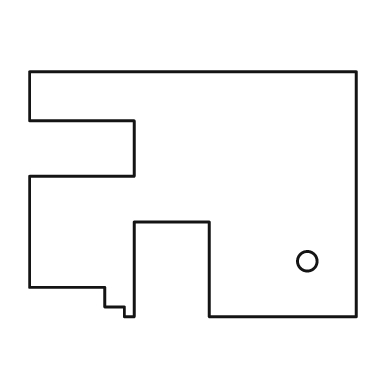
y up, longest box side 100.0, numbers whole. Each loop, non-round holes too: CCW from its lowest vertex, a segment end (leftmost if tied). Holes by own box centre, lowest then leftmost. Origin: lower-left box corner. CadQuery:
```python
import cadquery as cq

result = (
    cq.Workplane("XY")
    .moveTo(29.0, 0.0)
    .lineTo(32.0, 0.0)
    .lineTo(32.0, 29.0)
    .lineTo(55.0, 29.0)
    .lineTo(55.0, 0.0)
    .lineTo(100.0, 0.0)
    .lineTo(100.0, 75.0)
    .lineTo(0.0, 75.0)
    .lineTo(0.0, 60.0)
    .lineTo(32.0, 60.0)
    .lineTo(32.0, 43.0)
    .lineTo(0.0, 43.0)
    .lineTo(0.0, 9.0)
    .lineTo(23.0, 9.0)
    .lineTo(23.0, 3.0)
    .lineTo(29.0, 3.0)
    .close()
    .moveTo(85.0, 17.0)
    .circle(3.0)
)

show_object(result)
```